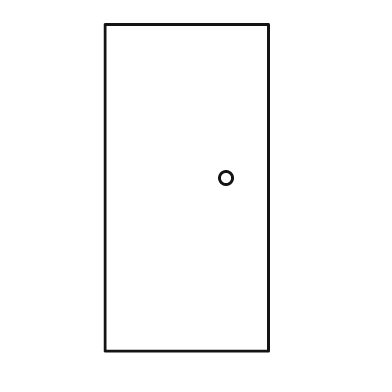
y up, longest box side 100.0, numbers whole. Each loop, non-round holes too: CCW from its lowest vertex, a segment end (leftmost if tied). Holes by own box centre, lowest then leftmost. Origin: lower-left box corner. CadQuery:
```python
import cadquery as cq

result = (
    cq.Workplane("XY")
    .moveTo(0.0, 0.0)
    .lineTo(50.0, 0.0)
    .lineTo(50.0, 100.0)
    .lineTo(0.0, 100.0)
    .close()
    .moveTo(37.0, 53.0)
    .circle(2.0)
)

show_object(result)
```